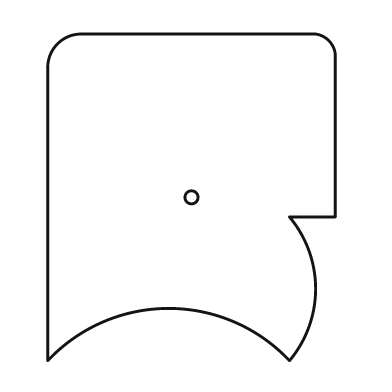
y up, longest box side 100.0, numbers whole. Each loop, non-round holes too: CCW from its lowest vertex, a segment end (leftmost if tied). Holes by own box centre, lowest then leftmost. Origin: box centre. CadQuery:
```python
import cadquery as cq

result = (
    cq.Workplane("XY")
    .moveTo(-44.0, -50.0)
    .threePointArc((-7.0, -34.0), (30.0, -50.0))
    .threePointArc((38.0, -28.0), (30.0, -6.0))
    .lineTo(44.0, -6.0)
    .lineTo(44.0, 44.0)
    .threePointArc((42.0, 48.0), (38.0, 50.0))
    .lineTo(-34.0, 50.0)
    .threePointArc((-41.0, 47.0), (-44.0, 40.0))
    .close()
    .moveTo(0.0, 0.0)
    .circle(2.0)
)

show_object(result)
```